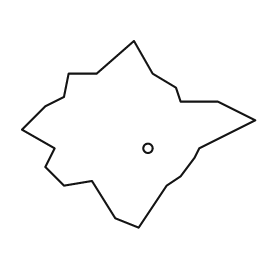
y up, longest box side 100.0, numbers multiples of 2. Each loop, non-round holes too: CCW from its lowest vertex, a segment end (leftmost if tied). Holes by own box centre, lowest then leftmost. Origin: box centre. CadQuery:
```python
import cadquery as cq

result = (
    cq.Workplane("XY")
    .moveTo(0.0, -40.0)
    .lineTo(12.0, -22.0)
    .lineTo(18.0, -18.0)
    .lineTo(24.0, -10.0)
    .lineTo(26.0, -6.0)
    .lineTo(50.0, 6.0)
    .lineTo(34.0, 14.0)
    .lineTo(18.0, 14.0)
    .lineTo(16.0, 20.0)
    .lineTo(6.0, 26.0)
    .lineTo(-2.0, 40.0)
    .lineTo(-18.0, 26.0)
    .lineTo(-30.0, 26.0)
    .lineTo(-32.0, 16.0)
    .lineTo(-40.0, 12.0)
    .lineTo(-50.0, 2.0)
    .lineTo(-36.0, -6.0)
    .lineTo(-40.0, -14.0)
    .lineTo(-32.0, -22.0)
    .lineTo(-20.0, -20.0)
    .lineTo(-10.0, -36.0)
    .close()
    .moveTo(4.0, -6.0)
    .circle(2.0)
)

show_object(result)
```